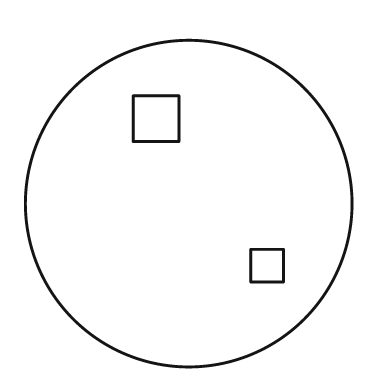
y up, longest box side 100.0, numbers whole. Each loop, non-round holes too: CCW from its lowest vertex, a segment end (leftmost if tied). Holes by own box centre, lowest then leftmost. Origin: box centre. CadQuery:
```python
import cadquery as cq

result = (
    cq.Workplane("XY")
    .moveTo(0.0, 0.0)
    .circle(50.0)
    .moveTo(19.0, -24.0)
    .lineTo(29.0, -24.0)
    .lineTo(29.0, -14.0)
    .lineTo(19.0, -14.0)
    .close()
    .moveTo(-17.0, 19.0)
    .lineTo(-3.0, 19.0)
    .lineTo(-3.0, 33.0)
    .lineTo(-17.0, 33.0)
    .close()
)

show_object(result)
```